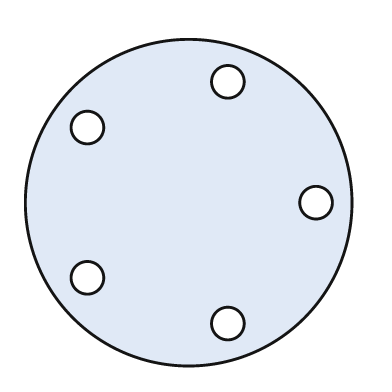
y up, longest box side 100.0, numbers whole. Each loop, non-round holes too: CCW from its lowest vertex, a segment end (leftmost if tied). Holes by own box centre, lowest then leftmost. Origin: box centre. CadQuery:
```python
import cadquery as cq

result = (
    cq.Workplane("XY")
    .moveTo(0.0, 0.0)
    .circle(50.0)
    .moveTo(12.0, -37.0)
    .circle(5.0)
    .moveTo(-31.0, -23.0)
    .circle(5.0)
    .moveTo(39.0, 0.0)
    .circle(5.0)
    .moveTo(-31.0, 23.0)
    .circle(5.0)
    .moveTo(12.0, 37.0)
    .circle(5.0)
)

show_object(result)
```